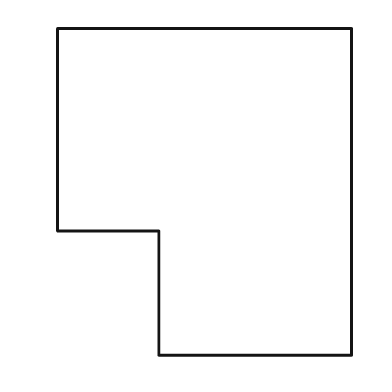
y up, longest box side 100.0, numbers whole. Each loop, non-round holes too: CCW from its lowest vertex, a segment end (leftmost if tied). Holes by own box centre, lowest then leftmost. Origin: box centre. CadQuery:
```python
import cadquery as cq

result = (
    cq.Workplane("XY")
    .moveTo(-14.0, -50.0)
    .lineTo(45.0, -50.0)
    .lineTo(45.0, 50.0)
    .lineTo(-45.0, 50.0)
    .lineTo(-45.0, -12.0)
    .lineTo(-14.0, -12.0)
    .close()
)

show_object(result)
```